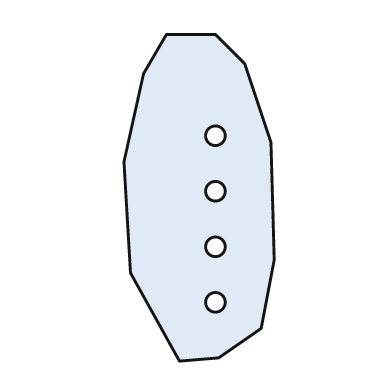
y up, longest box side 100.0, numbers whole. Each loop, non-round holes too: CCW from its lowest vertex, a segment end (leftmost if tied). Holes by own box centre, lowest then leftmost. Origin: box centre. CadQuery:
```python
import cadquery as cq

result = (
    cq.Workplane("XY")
    .moveTo(-6.0, -50.0)
    .lineTo(6.0, -49.0)
    .lineTo(19.0, -40.0)
    .lineTo(23.0, -19.0)
    .lineTo(22.0, 17.0)
    .lineTo(14.0, 41.0)
    .lineTo(5.0, 50.0)
    .lineTo(-10.0, 50.0)
    .lineTo(-17.0, 38.0)
    .lineTo(-23.0, 11.0)
    .lineTo(-21.0, -23.0)
    .close()
    .moveTo(5.0, -32.0)
    .circle(3.0)
    .moveTo(5.0, -15.0)
    .circle(3.0)
    .moveTo(5.0, 2.0)
    .circle(3.0)
    .moveTo(5.0, 19.0)
    .circle(3.0)
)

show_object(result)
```